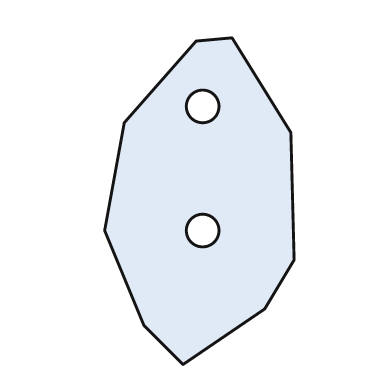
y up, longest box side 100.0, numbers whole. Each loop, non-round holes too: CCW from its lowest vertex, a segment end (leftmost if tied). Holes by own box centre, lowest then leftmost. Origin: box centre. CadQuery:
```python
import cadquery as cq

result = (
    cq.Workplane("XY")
    .moveTo(-5.0, -50.0)
    .lineTo(20.0, -33.0)
    .lineTo(29.0, -18.0)
    .lineTo(28.0, 21.0)
    .lineTo(10.0, 50.0)
    .lineTo(-1.0, 49.0)
    .lineTo(-23.0, 24.0)
    .lineTo(-29.0, -9.0)
    .lineTo(-17.0, -38.0)
    .close()
    .moveTo(1.0, -9.0)
    .circle(5.0)
    .moveTo(1.0, 29.0)
    .circle(5.0)
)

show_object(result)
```